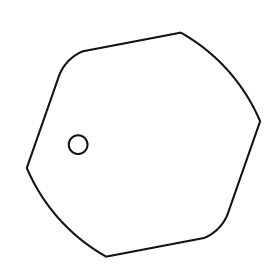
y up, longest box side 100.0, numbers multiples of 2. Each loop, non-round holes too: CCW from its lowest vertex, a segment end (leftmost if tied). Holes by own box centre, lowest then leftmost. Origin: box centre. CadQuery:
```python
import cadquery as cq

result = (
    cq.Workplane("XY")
    .moveTo(-16.0, -48.0)
    .lineTo(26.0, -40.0)
    .threePointArc((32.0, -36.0), (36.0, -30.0))
    .lineTo(50.0, 10.0)
    .threePointArc((36.0, 32.0), (16.0, 48.0))
    .lineTo(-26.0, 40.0)
    .threePointArc((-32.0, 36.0), (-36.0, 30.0))
    .lineTo(-50.0, -10.0)
    .threePointArc((-36.0, -32.0), (-16.0, -48.0))
    .close()
    .moveTo(-28.0, 0.0)
    .circle(4.0)
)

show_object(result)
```